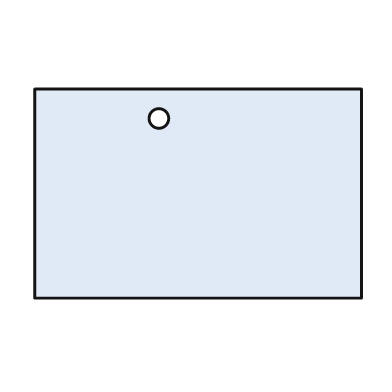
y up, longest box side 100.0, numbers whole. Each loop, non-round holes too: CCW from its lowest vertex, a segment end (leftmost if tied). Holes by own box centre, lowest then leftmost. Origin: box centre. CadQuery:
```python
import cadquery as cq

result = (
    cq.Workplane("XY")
    .moveTo(-50.0, -32.0)
    .lineTo(50.0, -32.0)
    .lineTo(50.0, 32.0)
    .lineTo(-50.0, 32.0)
    .close()
    .moveTo(-12.0, 23.0)
    .circle(3.0)
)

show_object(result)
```